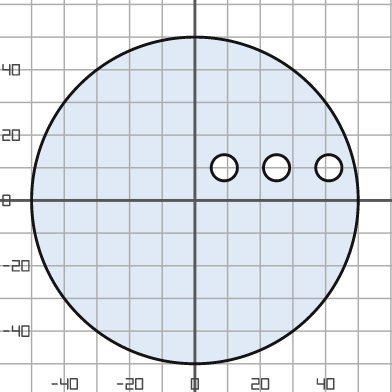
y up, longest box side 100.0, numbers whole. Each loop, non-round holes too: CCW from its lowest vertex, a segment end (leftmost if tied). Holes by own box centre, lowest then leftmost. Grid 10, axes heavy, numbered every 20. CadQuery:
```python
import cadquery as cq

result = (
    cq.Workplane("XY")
    .moveTo(0.0, 0.0)
    .circle(50.0)
    .moveTo(9.0, 10.0)
    .circle(4.0)
    .moveTo(25.0, 10.0)
    .circle(4.0)
    .moveTo(41.0, 10.0)
    .circle(4.0)
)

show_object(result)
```